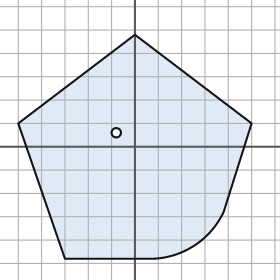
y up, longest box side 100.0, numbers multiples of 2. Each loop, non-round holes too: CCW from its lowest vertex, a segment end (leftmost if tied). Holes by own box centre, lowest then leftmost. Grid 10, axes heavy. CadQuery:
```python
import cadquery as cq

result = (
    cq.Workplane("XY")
    .moveTo(-30.0, -48.0)
    .lineTo(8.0, -48.0)
    .threePointArc((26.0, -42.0), (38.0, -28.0))
    .lineTo(50.0, 10.0)
    .lineTo(0.0, 48.0)
    .lineTo(-50.0, 10.0)
    .close()
    .moveTo(-8.0, 6.0)
    .circle(2.0)
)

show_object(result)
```